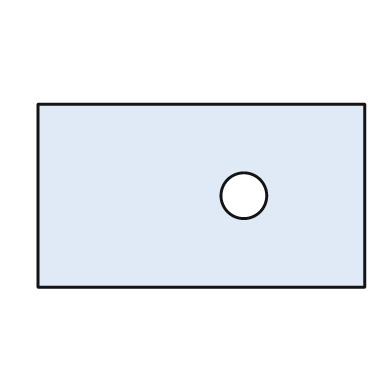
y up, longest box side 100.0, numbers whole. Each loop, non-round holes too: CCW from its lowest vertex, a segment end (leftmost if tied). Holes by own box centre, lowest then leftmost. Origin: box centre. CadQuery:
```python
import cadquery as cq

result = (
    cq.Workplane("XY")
    .moveTo(-50.0, -28.0)
    .lineTo(50.0, -28.0)
    .lineTo(50.0, 28.0)
    .lineTo(-50.0, 28.0)
    .close()
    .moveTo(13.0, 0.0)
    .circle(7.0)
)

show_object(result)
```